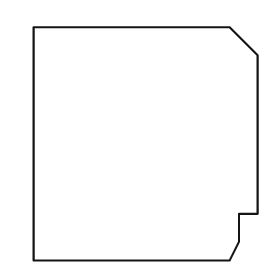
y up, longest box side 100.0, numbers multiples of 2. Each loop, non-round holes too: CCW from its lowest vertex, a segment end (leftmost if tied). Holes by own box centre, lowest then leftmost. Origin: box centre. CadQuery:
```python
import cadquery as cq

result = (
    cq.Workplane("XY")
    .moveTo(-48.0, -50.0)
    .lineTo(36.0, -50.0)
    .lineTo(40.0, -42.0)
    .lineTo(40.0, -30.0)
    .lineTo(48.0, -30.0)
    .lineTo(48.0, 38.0)
    .lineTo(36.0, 50.0)
    .lineTo(-48.0, 50.0)
    .close()
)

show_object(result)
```